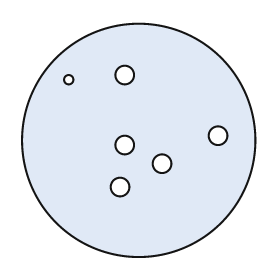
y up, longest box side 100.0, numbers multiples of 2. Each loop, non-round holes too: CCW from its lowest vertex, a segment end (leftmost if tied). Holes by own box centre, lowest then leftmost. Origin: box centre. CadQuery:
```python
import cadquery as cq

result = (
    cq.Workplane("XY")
    .moveTo(0.0, 0.0)
    .circle(50.0)
    .moveTo(-8.0, -20.0)
    .circle(4.0)
    .moveTo(10.0, -10.0)
    .circle(4.0)
    .moveTo(-6.0, -2.0)
    .circle(4.0)
    .moveTo(34.0, 2.0)
    .circle(4.0)
    .moveTo(-30.0, 26.0)
    .circle(2.0)
    .moveTo(-6.0, 28.0)
    .circle(4.0)
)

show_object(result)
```